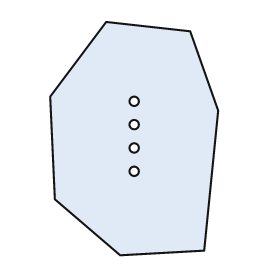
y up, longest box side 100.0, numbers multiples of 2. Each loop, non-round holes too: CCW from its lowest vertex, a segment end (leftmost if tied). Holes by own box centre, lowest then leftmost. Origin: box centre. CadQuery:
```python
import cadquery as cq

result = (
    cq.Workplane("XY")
    .moveTo(-6.0, -50.0)
    .lineTo(30.0, -48.0)
    .lineTo(36.0, 12.0)
    .lineTo(24.0, 46.0)
    .lineTo(-12.0, 50.0)
    .lineTo(-36.0, 18.0)
    .lineTo(-34.0, -26.0)
    .close()
    .moveTo(0.0, -14.0)
    .circle(2.0)
    .moveTo(0.0, -4.0)
    .circle(2.0)
    .moveTo(0.0, 6.0)
    .circle(2.0)
    .moveTo(0.0, 16.0)
    .circle(2.0)
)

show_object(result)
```